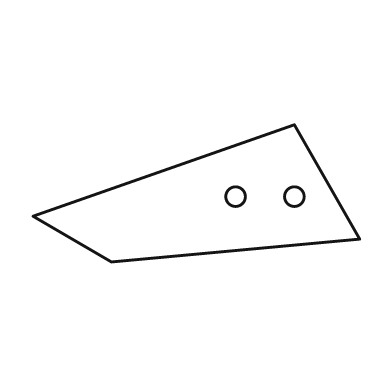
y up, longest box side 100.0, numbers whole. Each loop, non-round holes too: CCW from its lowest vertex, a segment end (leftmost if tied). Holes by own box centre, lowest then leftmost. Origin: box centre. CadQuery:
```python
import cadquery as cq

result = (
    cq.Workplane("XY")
    .moveTo(-26.0, -21.0)
    .lineTo(50.0, -14.0)
    .lineTo(30.0, 21.0)
    .lineTo(-50.0, -7.0)
    .close()
    .moveTo(12.0, -1.0)
    .circle(3.0)
    .moveTo(30.0, -1.0)
    .circle(3.0)
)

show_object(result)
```